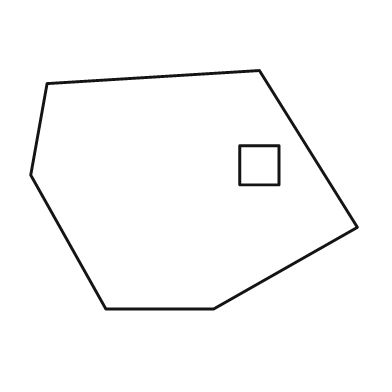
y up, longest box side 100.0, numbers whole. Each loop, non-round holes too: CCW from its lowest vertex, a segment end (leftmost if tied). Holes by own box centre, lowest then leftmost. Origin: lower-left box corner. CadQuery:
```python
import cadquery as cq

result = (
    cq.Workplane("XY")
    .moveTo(23.0, 0.0)
    .lineTo(56.0, 0.0)
    .lineTo(100.0, 25.0)
    .lineTo(70.0, 73.0)
    .lineTo(5.0, 69.0)
    .lineTo(0.0, 41.0)
    .close()
    .moveTo(64.0, 38.0)
    .lineTo(76.0, 38.0)
    .lineTo(76.0, 50.0)
    .lineTo(64.0, 50.0)
    .close()
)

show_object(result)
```